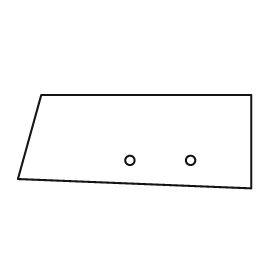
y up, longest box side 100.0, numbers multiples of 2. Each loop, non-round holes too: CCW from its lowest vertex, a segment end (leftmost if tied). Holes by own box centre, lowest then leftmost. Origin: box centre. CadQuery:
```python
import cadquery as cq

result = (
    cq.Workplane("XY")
    .moveTo(50.0, -20.0)
    .lineTo(50.0, 20.0)
    .lineTo(-40.0, 20.0)
    .lineTo(-50.0, -16.0)
    .close()
    .moveTo(-2.0, -8.0)
    .circle(2.0)
    .moveTo(24.0, -8.0)
    .circle(2.0)
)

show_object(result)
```